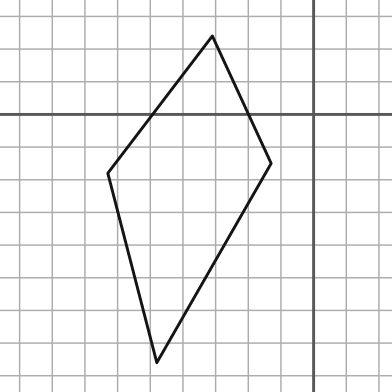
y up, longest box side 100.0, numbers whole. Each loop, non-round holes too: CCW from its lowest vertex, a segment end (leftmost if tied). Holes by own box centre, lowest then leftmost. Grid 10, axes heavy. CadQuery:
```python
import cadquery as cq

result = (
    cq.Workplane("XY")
    .moveTo(-48.0, -76.0)
    .lineTo(-13.0, -15.0)
    .lineTo(-31.0, 24.0)
    .lineTo(-63.0, -18.0)
    .close()
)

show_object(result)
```